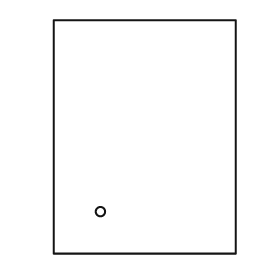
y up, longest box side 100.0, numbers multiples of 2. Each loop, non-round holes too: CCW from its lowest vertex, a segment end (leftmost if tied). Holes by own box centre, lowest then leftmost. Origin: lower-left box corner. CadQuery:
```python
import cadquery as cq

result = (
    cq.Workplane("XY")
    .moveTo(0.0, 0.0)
    .lineTo(78.0, 0.0)
    .lineTo(78.0, 100.0)
    .lineTo(0.0, 100.0)
    .close()
    .moveTo(20.0, 18.0)
    .circle(2.0)
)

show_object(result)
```